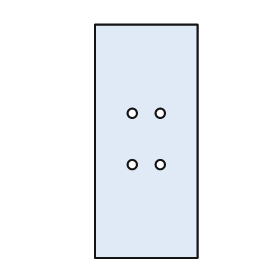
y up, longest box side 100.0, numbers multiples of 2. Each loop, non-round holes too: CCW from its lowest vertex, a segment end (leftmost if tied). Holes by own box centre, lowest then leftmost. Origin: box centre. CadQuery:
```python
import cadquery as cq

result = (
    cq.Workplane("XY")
    .moveTo(-22.0, -50.0)
    .lineTo(22.0, -50.0)
    .lineTo(22.0, 50.0)
    .lineTo(-22.0, 50.0)
    .close()
    .moveTo(-6.0, -10.0)
    .circle(2.0)
    .moveTo(6.0, -10.0)
    .circle(2.0)
    .moveTo(-6.0, 12.0)
    .circle(2.0)
    .moveTo(6.0, 12.0)
    .circle(2.0)
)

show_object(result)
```